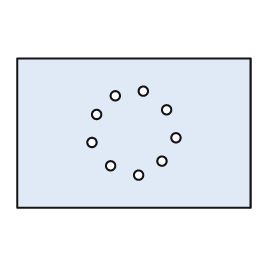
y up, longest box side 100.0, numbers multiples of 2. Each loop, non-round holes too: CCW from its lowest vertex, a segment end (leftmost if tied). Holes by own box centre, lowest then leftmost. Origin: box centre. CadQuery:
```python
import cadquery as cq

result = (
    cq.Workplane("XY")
    .moveTo(-50.0, -32.0)
    .lineTo(50.0, -32.0)
    .lineTo(50.0, 32.0)
    .lineTo(-50.0, 32.0)
    .close()
    .moveTo(2.0, -18.0)
    .circle(2.0)
    .moveTo(-10.0, -14.0)
    .circle(2.0)
    .moveTo(12.0, -12.0)
    .circle(2.0)
    .moveTo(-18.0, -4.0)
    .circle(2.0)
    .moveTo(18.0, -2.0)
    .circle(2.0)
    .moveTo(-16.0, 8.0)
    .circle(2.0)
    .moveTo(14.0, 10.0)
    .circle(2.0)
    .moveTo(-8.0, 16.0)
    .circle(2.0)
    .moveTo(4.0, 18.0)
    .circle(2.0)
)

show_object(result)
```